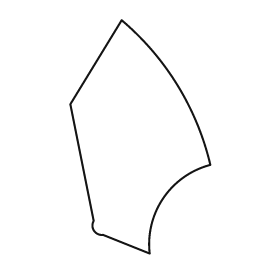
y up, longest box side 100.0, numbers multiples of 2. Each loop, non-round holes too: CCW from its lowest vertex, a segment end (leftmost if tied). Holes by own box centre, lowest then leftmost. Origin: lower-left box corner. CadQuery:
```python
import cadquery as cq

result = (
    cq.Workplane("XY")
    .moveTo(34.0, 0.0)
    .threePointArc((40.0, 24.0), (60.0, 38.0))
    .threePointArc((46.0, 72.0), (22.0, 100.0))
    .lineTo(0.0, 64.0)
    .lineTo(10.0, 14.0)
    .threePointArc((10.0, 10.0), (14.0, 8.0))
    .close()
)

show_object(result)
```